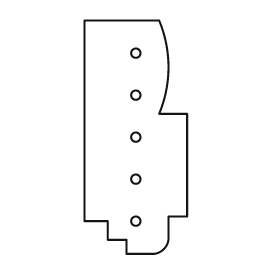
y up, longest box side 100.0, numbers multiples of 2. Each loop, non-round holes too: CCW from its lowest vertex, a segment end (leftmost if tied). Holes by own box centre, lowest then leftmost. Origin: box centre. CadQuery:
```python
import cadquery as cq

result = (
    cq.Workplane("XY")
    .moveTo(-4.0, -50.0)
    .lineTo(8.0, -50.0)
    .threePointArc((12.0, -48.0), (14.0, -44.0))
    .lineTo(14.0, -34.0)
    .lineTo(22.0, -34.0)
    .lineTo(22.0, 10.0)
    .lineTo(10.0, 10.0)
    .threePointArc((14.0, 30.0), (10.0, 50.0))
    .lineTo(-22.0, 50.0)
    .lineTo(-22.0, -36.0)
    .lineTo(-12.0, -36.0)
    .lineTo(-12.0, -44.0)
    .lineTo(-4.0, -44.0)
    .close()
    .moveTo(0.0, -36.0)
    .circle(2.0)
    .moveTo(0.0, -18.0)
    .circle(2.0)
    .moveTo(0.0, 0.0)
    .circle(2.0)
    .moveTo(0.0, 18.0)
    .circle(2.0)
    .moveTo(0.0, 36.0)
    .circle(2.0)
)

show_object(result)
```